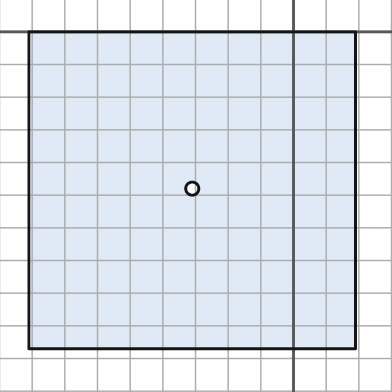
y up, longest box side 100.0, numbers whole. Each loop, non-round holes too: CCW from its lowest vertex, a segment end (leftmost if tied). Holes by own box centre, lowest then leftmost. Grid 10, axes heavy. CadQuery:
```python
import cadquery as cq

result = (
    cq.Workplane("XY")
    .moveTo(-81.0, -97.0)
    .lineTo(19.0, -97.0)
    .lineTo(19.0, 0.0)
    .lineTo(-81.0, 0.0)
    .close()
    .moveTo(-31.0, -48.0)
    .circle(2.0)
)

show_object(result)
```